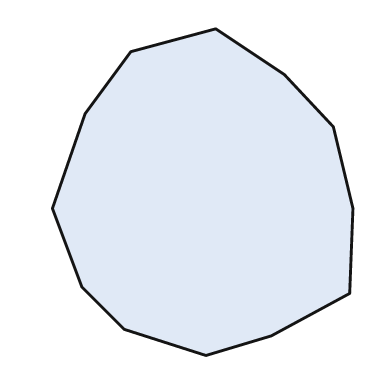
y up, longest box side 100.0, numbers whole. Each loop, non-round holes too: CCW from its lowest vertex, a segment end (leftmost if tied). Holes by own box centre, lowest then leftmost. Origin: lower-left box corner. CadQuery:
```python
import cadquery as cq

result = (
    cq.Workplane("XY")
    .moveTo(47.0, 0.0)
    .lineTo(67.0, 6.0)
    .lineTo(91.0, 19.0)
    .lineTo(92.0, 45.0)
    .lineTo(86.0, 70.0)
    .lineTo(71.0, 86.0)
    .lineTo(50.0, 100.0)
    .lineTo(24.0, 93.0)
    .lineTo(10.0, 74.0)
    .lineTo(0.0, 45.0)
    .lineTo(9.0, 21.0)
    .lineTo(22.0, 8.0)
    .close()
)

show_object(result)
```